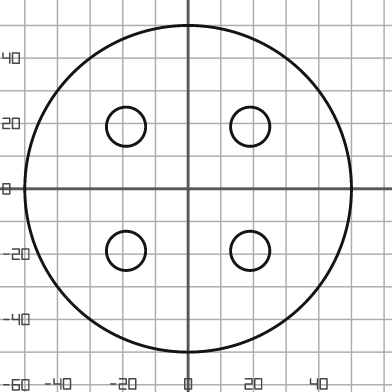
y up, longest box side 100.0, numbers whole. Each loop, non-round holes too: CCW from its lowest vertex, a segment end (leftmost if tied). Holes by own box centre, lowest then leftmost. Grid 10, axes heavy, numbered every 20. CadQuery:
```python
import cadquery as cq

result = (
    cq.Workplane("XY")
    .moveTo(0.0, 0.0)
    .circle(50.0)
    .moveTo(-19.0, -19.0)
    .circle(6.0)
    .moveTo(19.0, -19.0)
    .circle(6.0)
    .moveTo(-19.0, 19.0)
    .circle(6.0)
    .moveTo(19.0, 19.0)
    .circle(6.0)
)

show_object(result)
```